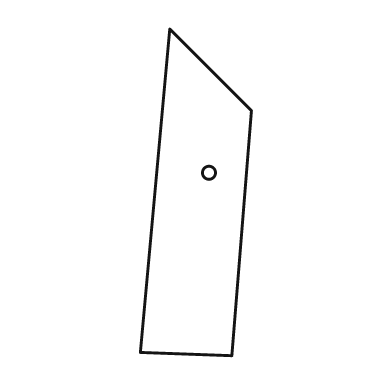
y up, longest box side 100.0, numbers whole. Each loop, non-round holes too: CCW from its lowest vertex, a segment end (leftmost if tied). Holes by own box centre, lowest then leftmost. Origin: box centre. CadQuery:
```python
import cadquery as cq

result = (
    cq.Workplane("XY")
    .moveTo(11.0, -50.0)
    .lineTo(17.0, 25.0)
    .lineTo(-8.0, 50.0)
    .lineTo(-17.0, -49.0)
    .close()
    .moveTo(4.0, 6.0)
    .circle(2.0)
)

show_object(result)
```